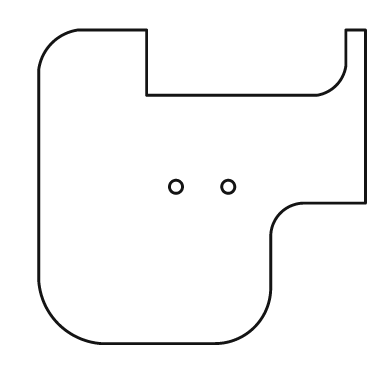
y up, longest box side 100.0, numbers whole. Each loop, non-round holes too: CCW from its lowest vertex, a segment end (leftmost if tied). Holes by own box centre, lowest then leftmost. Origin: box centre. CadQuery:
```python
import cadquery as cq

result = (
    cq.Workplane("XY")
    .moveTo(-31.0, -48.0)
    .lineTo(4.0, -48.0)
    .threePointArc((16.0, -43.0), (21.0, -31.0))
    .lineTo(21.0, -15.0)
    .threePointArc((24.0, -8.0), (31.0, -5.0))
    .lineTo(50.0, -5.0)
    .lineTo(50.0, 48.0)
    .lineTo(44.0, 48.0)
    .lineTo(44.0, 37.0)
    .threePointArc((41.0, 31.0), (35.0, 28.0))
    .lineTo(-17.0, 28.0)
    .lineTo(-17.0, 48.0)
    .lineTo(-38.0, 48.0)
    .threePointArc((-46.0, 44.0), (-50.0, 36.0))
    .lineTo(-50.0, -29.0)
    .threePointArc((-44.0, -42.0), (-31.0, -48.0))
    .close()
    .moveTo(-8.0, 0.0)
    .circle(2.0)
    .moveTo(8.0, 0.0)
    .circle(2.0)
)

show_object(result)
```